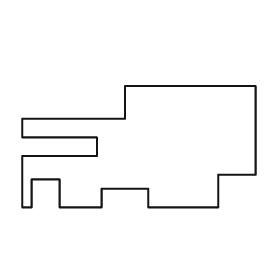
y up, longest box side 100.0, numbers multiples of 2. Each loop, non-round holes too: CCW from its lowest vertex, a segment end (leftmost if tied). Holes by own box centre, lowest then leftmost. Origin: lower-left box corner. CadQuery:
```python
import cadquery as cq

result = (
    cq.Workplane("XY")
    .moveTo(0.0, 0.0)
    .lineTo(4.0, 0.0)
    .lineTo(4.0, 12.0)
    .lineTo(16.0, 12.0)
    .lineTo(16.0, 0.0)
    .lineTo(34.0, 0.0)
    .lineTo(34.0, 8.0)
    .lineTo(54.0, 8.0)
    .lineTo(54.0, 0.0)
    .lineTo(84.0, 0.0)
    .lineTo(84.0, 14.0)
    .lineTo(100.0, 14.0)
    .lineTo(100.0, 52.0)
    .lineTo(44.0, 52.0)
    .lineTo(44.0, 38.0)
    .lineTo(0.0, 38.0)
    .lineTo(0.0, 30.0)
    .lineTo(32.0, 30.0)
    .lineTo(32.0, 22.0)
    .lineTo(0.0, 22.0)
    .close()
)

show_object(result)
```